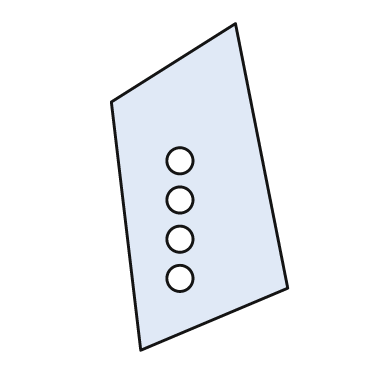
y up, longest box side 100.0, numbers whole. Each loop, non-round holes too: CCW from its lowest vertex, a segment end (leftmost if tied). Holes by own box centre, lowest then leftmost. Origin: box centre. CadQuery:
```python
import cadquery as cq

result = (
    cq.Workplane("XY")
    .moveTo(-18.0, -50.0)
    .lineTo(27.0, -31.0)
    .lineTo(11.0, 50.0)
    .lineTo(-27.0, 26.0)
    .close()
    .moveTo(-6.0, -28.0)
    .circle(4.0)
    .moveTo(-6.0, -16.0)
    .circle(4.0)
    .moveTo(-6.0, -4.0)
    .circle(4.0)
    .moveTo(-6.0, 8.0)
    .circle(4.0)
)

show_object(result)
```